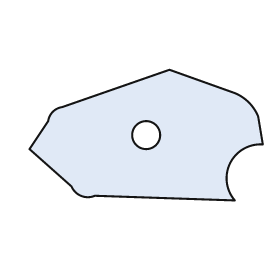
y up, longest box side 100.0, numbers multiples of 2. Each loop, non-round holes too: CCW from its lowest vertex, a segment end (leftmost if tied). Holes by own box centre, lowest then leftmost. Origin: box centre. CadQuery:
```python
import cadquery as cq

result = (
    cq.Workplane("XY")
    .moveTo(38.0, -28.0)
    .threePointArc((36.0, -12.0), (50.0, -4.0))
    .lineTo(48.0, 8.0)
    .threePointArc((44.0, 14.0), (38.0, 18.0))
    .lineTo(10.0, 28.0)
    .lineTo(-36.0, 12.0)
    .threePointArc((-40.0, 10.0), (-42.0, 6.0))
    .lineTo(-50.0, -6.0)
    .lineTo(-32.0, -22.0)
    .threePointArc((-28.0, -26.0), (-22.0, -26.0))
    .close()
    .moveTo(0.0, 0.0)
    .circle(6.0)
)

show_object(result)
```